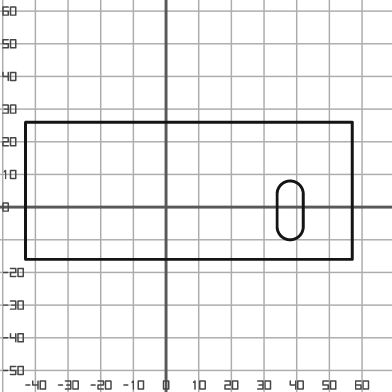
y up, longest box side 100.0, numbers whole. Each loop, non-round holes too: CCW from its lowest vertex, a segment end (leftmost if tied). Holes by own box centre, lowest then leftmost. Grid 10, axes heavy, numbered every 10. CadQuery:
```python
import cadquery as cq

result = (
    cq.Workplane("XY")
    .moveTo(-43.0, -16.0)
    .lineTo(57.0, -16.0)
    .lineTo(57.0, 26.0)
    .lineTo(-43.0, 26.0)
    .close()
    .moveTo(34.0, -6.0)
    .threePointArc((38.0, -10.0), (42.0, -6.0))
    .lineTo(42.0, 4.0)
    .threePointArc((38.0, 8.0), (34.0, 4.0))
    .close()
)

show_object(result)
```